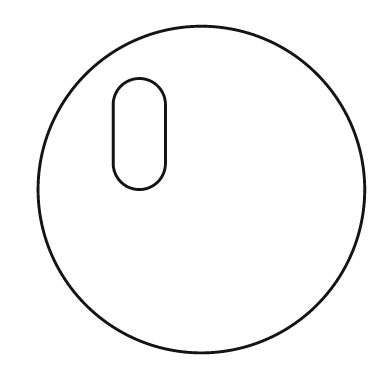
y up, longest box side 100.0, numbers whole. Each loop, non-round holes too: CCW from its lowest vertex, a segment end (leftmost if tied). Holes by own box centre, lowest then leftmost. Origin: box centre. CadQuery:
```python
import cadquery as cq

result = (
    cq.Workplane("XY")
    .moveTo(0.0, 0.0)
    .circle(50.0)
    .moveTo(-27.0, 8.0)
    .threePointArc((-19.0, 0.0), (-11.0, 8.0))
    .lineTo(-11.0, 26.0)
    .threePointArc((-19.0, 34.0), (-27.0, 26.0))
    .close()
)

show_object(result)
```